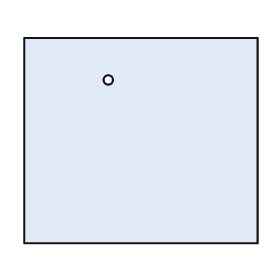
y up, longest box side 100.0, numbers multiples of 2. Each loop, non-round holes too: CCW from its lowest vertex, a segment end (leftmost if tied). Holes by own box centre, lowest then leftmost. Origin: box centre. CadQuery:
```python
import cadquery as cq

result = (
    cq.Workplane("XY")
    .moveTo(-50.0, -44.0)
    .lineTo(50.0, -44.0)
    .lineTo(50.0, 44.0)
    .lineTo(-50.0, 44.0)
    .close()
    .moveTo(-14.0, 26.0)
    .circle(2.0)
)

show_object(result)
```